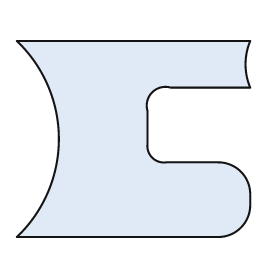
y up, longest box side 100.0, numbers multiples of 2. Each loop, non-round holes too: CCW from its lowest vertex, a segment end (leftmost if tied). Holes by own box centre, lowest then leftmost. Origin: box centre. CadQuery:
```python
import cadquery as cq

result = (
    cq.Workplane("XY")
    .moveTo(-50.0, -42.0)
    .lineTo(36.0, -42.0)
    .threePointArc((46.0, -38.0), (50.0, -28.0))
    .lineTo(50.0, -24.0)
    .threePointArc((46.0, -14.0), (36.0, -10.0))
    .lineTo(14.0, -10.0)
    .threePointArc((8.0, -8.0), (6.0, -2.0))
    .lineTo(6.0, 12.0)
    .threePointArc((8.0, 20.0), (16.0, 22.0))
    .lineTo(50.0, 22.0)
    .threePointArc((48.0, 32.0), (50.0, 42.0))
    .lineTo(-50.0, 42.0)
    .threePointArc((-32.0, 0.0), (-50.0, -42.0))
    .close()
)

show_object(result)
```